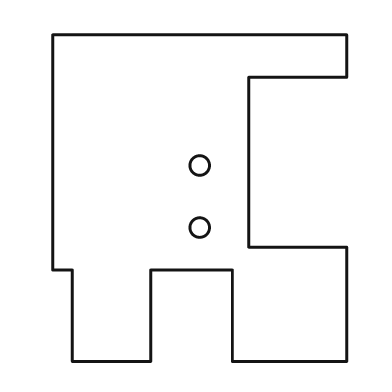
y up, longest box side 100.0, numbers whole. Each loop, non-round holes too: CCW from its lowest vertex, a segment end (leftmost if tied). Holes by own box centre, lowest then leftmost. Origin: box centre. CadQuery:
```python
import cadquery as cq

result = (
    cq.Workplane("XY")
    .moveTo(-39.0, -50.0)
    .lineTo(-15.0, -50.0)
    .lineTo(-15.0, -22.0)
    .lineTo(10.0, -22.0)
    .lineTo(10.0, -50.0)
    .lineTo(45.0, -50.0)
    .lineTo(45.0, -15.0)
    .lineTo(15.0, -15.0)
    .lineTo(15.0, 37.0)
    .lineTo(45.0, 37.0)
    .lineTo(45.0, 50.0)
    .lineTo(-45.0, 50.0)
    .lineTo(-45.0, -22.0)
    .lineTo(-39.0, -22.0)
    .close()
    .moveTo(0.0, -9.0)
    .circle(3.0)
    .moveTo(0.0, 10.0)
    .circle(3.0)
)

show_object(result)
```